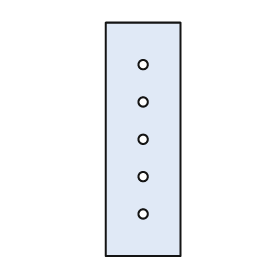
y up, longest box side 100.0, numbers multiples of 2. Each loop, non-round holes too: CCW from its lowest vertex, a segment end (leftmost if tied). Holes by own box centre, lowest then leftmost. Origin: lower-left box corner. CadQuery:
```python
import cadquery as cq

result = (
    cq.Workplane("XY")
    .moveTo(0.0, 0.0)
    .lineTo(32.0, 0.0)
    .lineTo(32.0, 100.0)
    .lineTo(0.0, 100.0)
    .close()
    .moveTo(16.0, 18.0)
    .circle(2.0)
    .moveTo(16.0, 34.0)
    .circle(2.0)
    .moveTo(16.0, 50.0)
    .circle(2.0)
    .moveTo(16.0, 66.0)
    .circle(2.0)
    .moveTo(16.0, 82.0)
    .circle(2.0)
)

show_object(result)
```